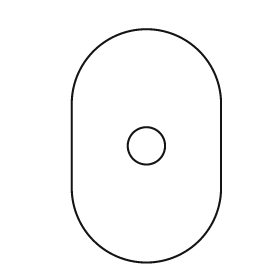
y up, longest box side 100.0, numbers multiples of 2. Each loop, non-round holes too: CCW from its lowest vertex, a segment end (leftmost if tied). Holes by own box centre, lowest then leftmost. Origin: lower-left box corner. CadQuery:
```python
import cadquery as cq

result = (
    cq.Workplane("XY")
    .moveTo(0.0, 32.0)
    .threePointArc((32.0, 0.0), (64.0, 32.0))
    .lineTo(64.0, 68.0)
    .threePointArc((32.0, 100.0), (0.0, 68.0))
    .close()
    .moveTo(32.0, 50.0)
    .circle(8.0)
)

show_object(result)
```